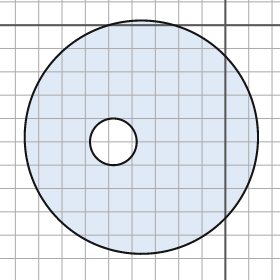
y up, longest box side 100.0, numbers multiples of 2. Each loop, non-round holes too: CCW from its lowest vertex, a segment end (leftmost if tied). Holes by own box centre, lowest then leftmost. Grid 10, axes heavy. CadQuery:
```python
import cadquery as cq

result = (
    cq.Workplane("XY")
    .moveTo(-36.0, -48.0)
    .circle(50.0)
    .moveTo(-48.0, -50.0)
    .circle(10.0)
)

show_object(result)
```